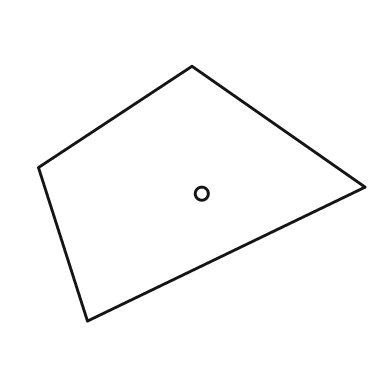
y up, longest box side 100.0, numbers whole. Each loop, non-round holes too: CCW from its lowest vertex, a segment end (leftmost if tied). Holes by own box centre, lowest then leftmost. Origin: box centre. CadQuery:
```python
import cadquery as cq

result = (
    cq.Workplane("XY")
    .moveTo(-35.0, -39.0)
    .lineTo(50.0, 2.0)
    .lineTo(-3.0, 39.0)
    .lineTo(-50.0, 8.0)
    .close()
    .moveTo(0.0, 0.0)
    .circle(2.0)
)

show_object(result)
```